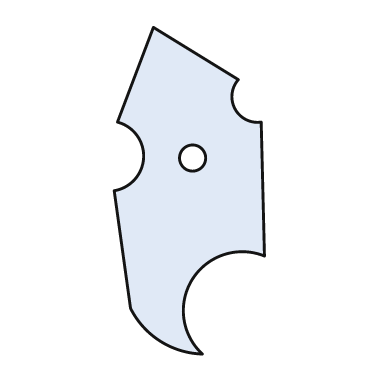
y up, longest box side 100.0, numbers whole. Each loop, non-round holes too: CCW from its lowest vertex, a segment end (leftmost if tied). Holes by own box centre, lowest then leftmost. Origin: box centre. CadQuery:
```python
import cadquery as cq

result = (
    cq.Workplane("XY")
    .moveTo(4.0, -50.0)
    .threePointArc((1.0, -27.0), (23.0, -20.0))
    .lineTo(22.0, 21.0)
    .threePointArc((14.0, 25.0), (15.0, 34.0))
    .lineTo(-11.0, 50.0)
    .lineTo(-22.0, 21.0)
    .threePointArc((-14.0, 10.0), (-23.0, 0.0))
    .lineTo(-18.0, -36.0)
    .threePointArc((-9.0, -46.0), (4.0, -50.0))
    .close()
    .moveTo(1.0, 10.0)
    .circle(4.0)
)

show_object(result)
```